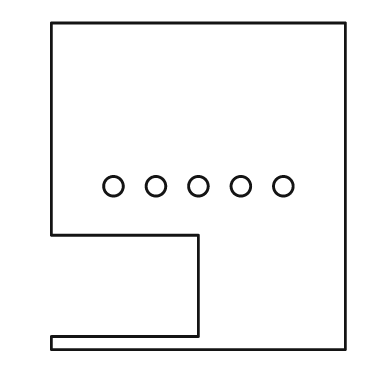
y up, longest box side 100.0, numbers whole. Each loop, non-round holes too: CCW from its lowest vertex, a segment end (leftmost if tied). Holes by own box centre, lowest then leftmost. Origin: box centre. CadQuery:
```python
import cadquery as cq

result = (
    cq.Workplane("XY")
    .moveTo(-45.0, -50.0)
    .lineTo(45.0, -50.0)
    .lineTo(45.0, 50.0)
    .lineTo(-45.0, 50.0)
    .lineTo(-45.0, -15.0)
    .lineTo(0.0, -15.0)
    .lineTo(0.0, -46.0)
    .lineTo(-45.0, -46.0)
    .close()
    .moveTo(-26.0, 0.0)
    .circle(3.0)
    .moveTo(-13.0, 0.0)
    .circle(3.0)
    .moveTo(0.0, 0.0)
    .circle(3.0)
    .moveTo(13.0, 0.0)
    .circle(3.0)
    .moveTo(26.0, 0.0)
    .circle(3.0)
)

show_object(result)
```